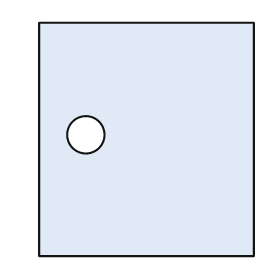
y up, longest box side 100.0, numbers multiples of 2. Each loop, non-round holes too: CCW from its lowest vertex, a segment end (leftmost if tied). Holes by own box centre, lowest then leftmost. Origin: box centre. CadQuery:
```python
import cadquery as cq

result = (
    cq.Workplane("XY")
    .moveTo(-46.0, -50.0)
    .lineTo(46.0, -50.0)
    .lineTo(46.0, 50.0)
    .lineTo(-46.0, 50.0)
    .close()
    .moveTo(-26.0, 2.0)
    .circle(8.0)
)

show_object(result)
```